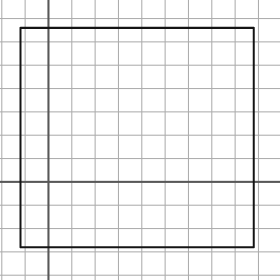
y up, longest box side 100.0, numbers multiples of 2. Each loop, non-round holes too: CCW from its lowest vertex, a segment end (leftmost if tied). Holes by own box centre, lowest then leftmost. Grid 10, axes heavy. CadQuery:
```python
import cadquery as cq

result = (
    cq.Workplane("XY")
    .moveTo(-12.0, -28.0)
    .lineTo(88.0, -28.0)
    .lineTo(88.0, 66.0)
    .lineTo(-12.0, 66.0)
    .close()
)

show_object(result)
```